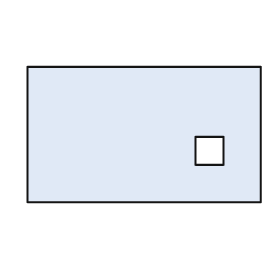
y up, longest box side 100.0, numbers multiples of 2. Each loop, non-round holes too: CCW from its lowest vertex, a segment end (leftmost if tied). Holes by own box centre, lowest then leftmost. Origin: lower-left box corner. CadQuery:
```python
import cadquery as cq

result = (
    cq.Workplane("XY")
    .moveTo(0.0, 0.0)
    .lineTo(100.0, 0.0)
    .lineTo(100.0, 58.0)
    .lineTo(0.0, 58.0)
    .close()
    .moveTo(72.0, 16.0)
    .lineTo(84.0, 16.0)
    .lineTo(84.0, 28.0)
    .lineTo(72.0, 28.0)
    .close()
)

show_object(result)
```